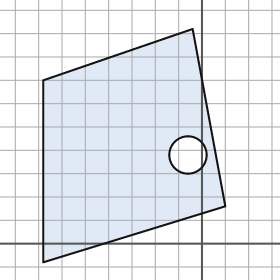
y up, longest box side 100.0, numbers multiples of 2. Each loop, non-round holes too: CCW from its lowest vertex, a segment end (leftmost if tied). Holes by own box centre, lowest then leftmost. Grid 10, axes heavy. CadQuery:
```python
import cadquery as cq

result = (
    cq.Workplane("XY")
    .moveTo(-68.0, -8.0)
    .lineTo(10.0, 16.0)
    .lineTo(-4.0, 92.0)
    .lineTo(-68.0, 70.0)
    .close()
    .moveTo(-6.0, 38.0)
    .circle(8.0)
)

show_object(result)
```